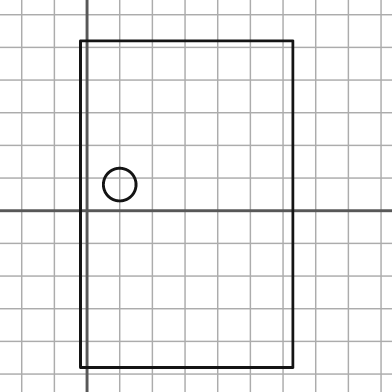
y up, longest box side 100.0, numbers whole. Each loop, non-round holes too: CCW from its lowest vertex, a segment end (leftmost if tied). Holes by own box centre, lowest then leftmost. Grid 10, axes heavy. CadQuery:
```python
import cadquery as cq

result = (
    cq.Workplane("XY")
    .moveTo(-2.0, -48.0)
    .lineTo(63.0, -48.0)
    .lineTo(63.0, 52.0)
    .lineTo(-2.0, 52.0)
    .close()
    .moveTo(10.0, 8.0)
    .circle(5.0)
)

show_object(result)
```